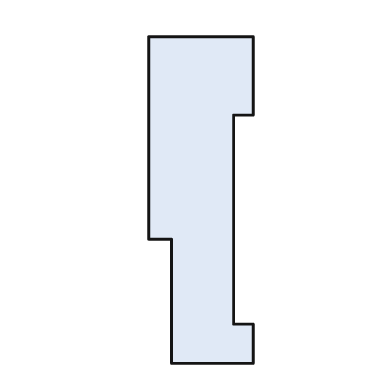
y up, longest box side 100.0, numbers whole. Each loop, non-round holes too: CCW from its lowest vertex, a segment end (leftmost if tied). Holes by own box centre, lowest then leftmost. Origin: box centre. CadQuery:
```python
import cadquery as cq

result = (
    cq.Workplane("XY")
    .moveTo(-9.0, -50.0)
    .lineTo(16.0, -50.0)
    .lineTo(16.0, -38.0)
    .lineTo(10.0, -38.0)
    .lineTo(10.0, 26.0)
    .lineTo(16.0, 26.0)
    .lineTo(16.0, 50.0)
    .lineTo(-16.0, 50.0)
    .lineTo(-16.0, -12.0)
    .lineTo(-9.0, -12.0)
    .close()
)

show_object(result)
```